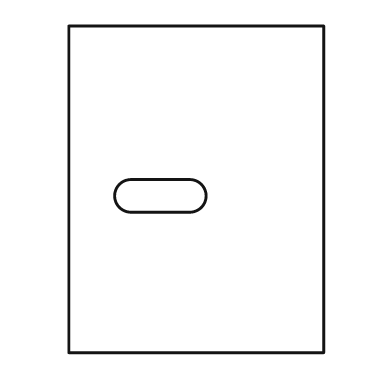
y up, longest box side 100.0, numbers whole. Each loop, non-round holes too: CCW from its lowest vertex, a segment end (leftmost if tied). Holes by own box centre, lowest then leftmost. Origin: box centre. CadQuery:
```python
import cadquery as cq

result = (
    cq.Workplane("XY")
    .moveTo(-39.0, -50.0)
    .lineTo(39.0, -50.0)
    .lineTo(39.0, 50.0)
    .lineTo(-39.0, 50.0)
    .close()
    .moveTo(-20.0, -7.0)
    .lineTo(-2.0, -7.0)
    .threePointArc((3.0, -2.0), (-2.0, 3.0))
    .lineTo(-20.0, 3.0)
    .threePointArc((-25.0, -2.0), (-20.0, -7.0))
    .close()
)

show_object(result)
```